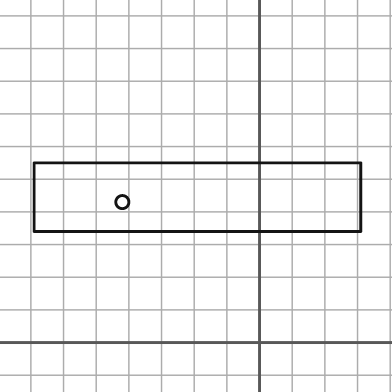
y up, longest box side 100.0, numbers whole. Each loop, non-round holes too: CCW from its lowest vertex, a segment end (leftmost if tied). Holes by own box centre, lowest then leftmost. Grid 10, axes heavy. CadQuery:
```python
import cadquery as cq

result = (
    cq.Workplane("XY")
    .moveTo(-69.0, 34.0)
    .lineTo(31.0, 34.0)
    .lineTo(31.0, 55.0)
    .lineTo(-69.0, 55.0)
    .close()
    .moveTo(-42.0, 43.0)
    .circle(2.0)
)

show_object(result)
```